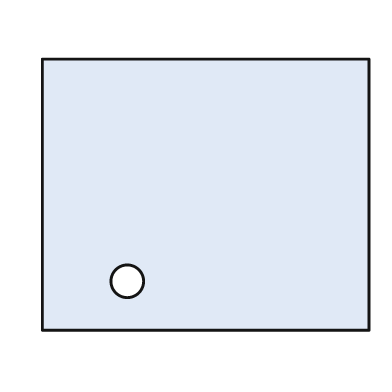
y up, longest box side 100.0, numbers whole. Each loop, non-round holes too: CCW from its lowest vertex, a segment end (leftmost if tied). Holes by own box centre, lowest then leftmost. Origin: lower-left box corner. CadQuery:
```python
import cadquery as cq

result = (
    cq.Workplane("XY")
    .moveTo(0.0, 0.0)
    .lineTo(100.0, 0.0)
    .lineTo(100.0, 83.0)
    .lineTo(0.0, 83.0)
    .close()
    .moveTo(26.0, 15.0)
    .circle(5.0)
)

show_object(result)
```